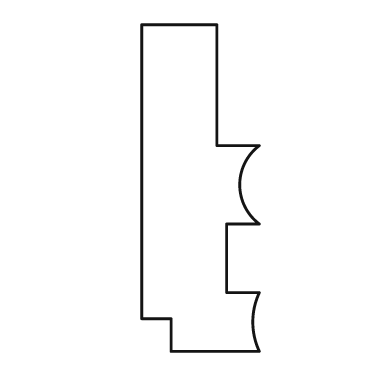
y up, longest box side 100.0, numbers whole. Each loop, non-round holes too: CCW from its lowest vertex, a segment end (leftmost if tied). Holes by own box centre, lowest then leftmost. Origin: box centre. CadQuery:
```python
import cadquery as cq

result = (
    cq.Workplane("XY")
    .moveTo(-9.0, -50.0)
    .lineTo(18.0, -50.0)
    .threePointArc((16.0, -41.0), (18.0, -32.0))
    .lineTo(8.0, -32.0)
    .lineTo(8.0, -11.0)
    .lineTo(18.0, -11.0)
    .threePointArc((12.0, 1.0), (18.0, 13.0))
    .lineTo(5.0, 13.0)
    .lineTo(5.0, 50.0)
    .lineTo(-18.0, 50.0)
    .lineTo(-18.0, -40.0)
    .lineTo(-9.0, -40.0)
    .close()
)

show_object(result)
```